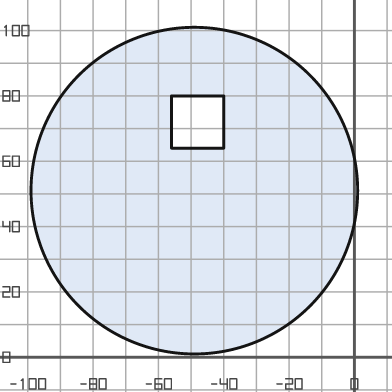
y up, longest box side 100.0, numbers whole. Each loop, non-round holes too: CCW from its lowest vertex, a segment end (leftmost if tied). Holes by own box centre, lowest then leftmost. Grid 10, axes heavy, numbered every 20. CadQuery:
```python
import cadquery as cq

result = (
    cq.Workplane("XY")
    .moveTo(-49.0, 51.0)
    .circle(50.0)
    .moveTo(-56.0, 64.0)
    .lineTo(-40.0, 64.0)
    .lineTo(-40.0, 80.0)
    .lineTo(-56.0, 80.0)
    .close()
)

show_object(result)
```